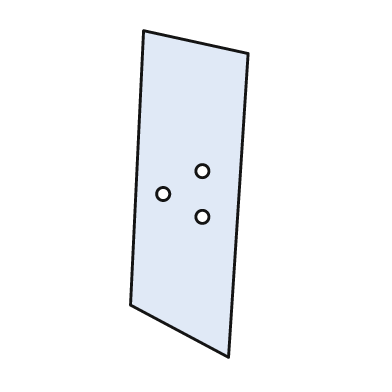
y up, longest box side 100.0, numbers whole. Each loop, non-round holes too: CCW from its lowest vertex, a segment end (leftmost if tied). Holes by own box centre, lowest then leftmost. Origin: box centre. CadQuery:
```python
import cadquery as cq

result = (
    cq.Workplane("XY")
    .moveTo(12.0, -50.0)
    .lineTo(18.0, 43.0)
    .lineTo(-14.0, 50.0)
    .lineTo(-18.0, -34.0)
    .close()
    .moveTo(4.0, -7.0)
    .circle(2.0)
    .moveTo(-8.0, 0.0)
    .circle(2.0)
    .moveTo(4.0, 7.0)
    .circle(2.0)
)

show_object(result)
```